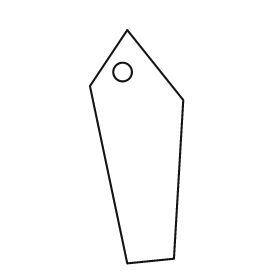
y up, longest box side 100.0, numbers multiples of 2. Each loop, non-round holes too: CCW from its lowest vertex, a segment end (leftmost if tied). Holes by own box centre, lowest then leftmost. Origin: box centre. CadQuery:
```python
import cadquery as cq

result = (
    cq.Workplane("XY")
    .moveTo(-4.0, -50.0)
    .lineTo(16.0, -48.0)
    .lineTo(20.0, 20.0)
    .lineTo(-4.0, 50.0)
    .lineTo(-20.0, 26.0)
    .close()
    .moveTo(-6.0, 32.0)
    .circle(4.0)
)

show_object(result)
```